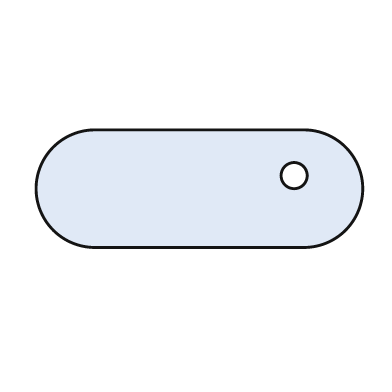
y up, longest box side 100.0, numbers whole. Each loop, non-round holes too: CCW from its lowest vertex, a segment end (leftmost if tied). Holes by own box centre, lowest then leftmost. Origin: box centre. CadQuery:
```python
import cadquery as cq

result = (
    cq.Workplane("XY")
    .moveTo(-32.0, -18.0)
    .lineTo(32.0, -18.0)
    .threePointArc((50.0, 0.0), (32.0, 18.0))
    .lineTo(-32.0, 18.0)
    .threePointArc((-50.0, 0.0), (-32.0, -18.0))
    .close()
    .moveTo(29.0, 4.0)
    .circle(4.0)
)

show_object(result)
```